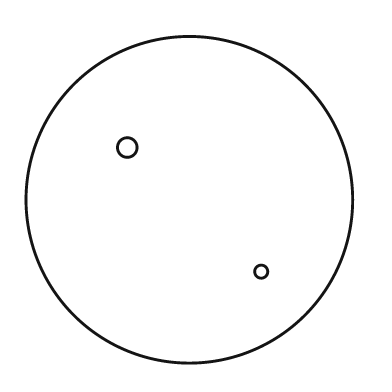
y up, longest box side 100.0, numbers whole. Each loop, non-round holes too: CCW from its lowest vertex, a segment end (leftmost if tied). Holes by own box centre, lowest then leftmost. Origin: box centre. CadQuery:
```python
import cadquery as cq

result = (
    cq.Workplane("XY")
    .moveTo(0.0, 0.0)
    .circle(50.0)
    .moveTo(22.0, -22.0)
    .circle(2.0)
    .moveTo(-19.0, 16.0)
    .circle(3.0)
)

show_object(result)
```